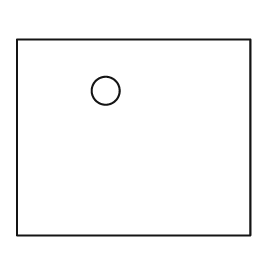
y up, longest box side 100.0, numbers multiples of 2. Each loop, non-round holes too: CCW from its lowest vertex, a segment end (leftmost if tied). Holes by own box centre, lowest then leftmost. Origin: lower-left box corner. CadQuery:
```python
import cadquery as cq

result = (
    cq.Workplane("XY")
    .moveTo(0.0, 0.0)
    .lineTo(100.0, 0.0)
    .lineTo(100.0, 84.0)
    .lineTo(0.0, 84.0)
    .close()
    .moveTo(38.0, 62.0)
    .circle(6.0)
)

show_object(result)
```